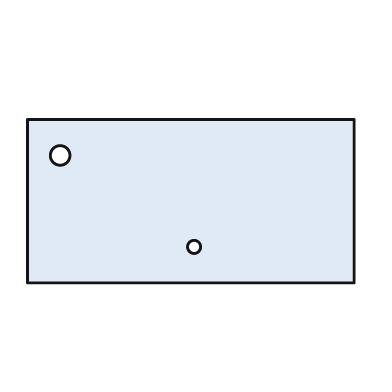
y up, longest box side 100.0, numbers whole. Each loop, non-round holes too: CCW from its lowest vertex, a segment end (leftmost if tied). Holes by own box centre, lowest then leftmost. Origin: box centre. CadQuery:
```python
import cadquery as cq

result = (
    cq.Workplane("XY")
    .moveTo(-50.0, -25.0)
    .lineTo(50.0, -25.0)
    .lineTo(50.0, 25.0)
    .lineTo(-50.0, 25.0)
    .close()
    .moveTo(1.0, -14.0)
    .circle(2.0)
    .moveTo(-40.0, 14.0)
    .circle(3.0)
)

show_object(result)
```